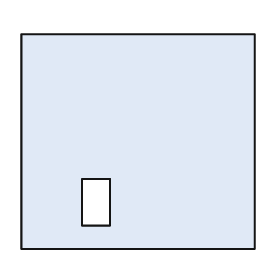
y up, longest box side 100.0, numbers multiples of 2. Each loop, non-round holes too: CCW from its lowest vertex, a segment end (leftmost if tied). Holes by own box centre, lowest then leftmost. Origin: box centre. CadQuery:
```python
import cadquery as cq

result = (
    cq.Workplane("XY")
    .moveTo(-50.0, -46.0)
    .lineTo(50.0, -46.0)
    .lineTo(50.0, 46.0)
    .lineTo(-50.0, 46.0)
    .close()
    .moveTo(-24.0, -36.0)
    .lineTo(-12.0, -36.0)
    .lineTo(-12.0, -16.0)
    .lineTo(-24.0, -16.0)
    .close()
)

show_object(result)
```